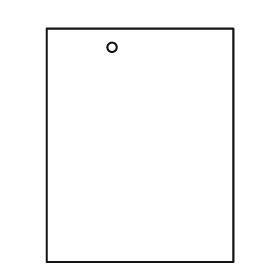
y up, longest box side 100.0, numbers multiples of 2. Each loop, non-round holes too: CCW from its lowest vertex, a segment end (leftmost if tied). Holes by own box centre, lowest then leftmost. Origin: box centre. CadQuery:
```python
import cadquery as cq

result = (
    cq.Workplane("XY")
    .moveTo(-40.0, -50.0)
    .lineTo(40.0, -50.0)
    .lineTo(40.0, 50.0)
    .lineTo(-40.0, 50.0)
    .close()
    .moveTo(-12.0, 42.0)
    .circle(2.0)
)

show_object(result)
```